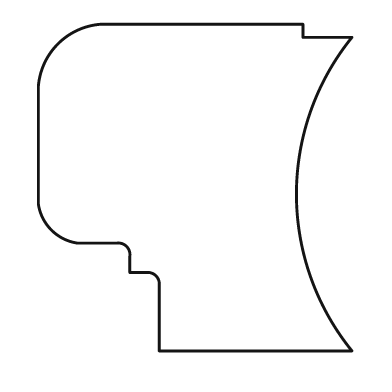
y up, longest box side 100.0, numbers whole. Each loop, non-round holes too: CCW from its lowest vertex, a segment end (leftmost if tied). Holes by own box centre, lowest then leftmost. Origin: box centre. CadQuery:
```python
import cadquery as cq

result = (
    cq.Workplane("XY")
    .moveTo(-11.0, -50.0)
    .lineTo(48.0, -50.0)
    .threePointArc((31.0, -2.0), (48.0, 46.0))
    .lineTo(33.0, 46.0)
    .lineTo(33.0, 50.0)
    .lineTo(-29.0, 50.0)
    .threePointArc((-42.0, 44.0), (-48.0, 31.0))
    .lineTo(-48.0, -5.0)
    .threePointArc((-44.0, -13.0), (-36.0, -17.0))
    .lineTo(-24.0, -17.0)
    .threePointArc((-21.0, -18.0), (-20.0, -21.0))
    .lineTo(-20.0, -26.0)
    .lineTo(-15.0, -26.0)
    .threePointArc((-12.0, -27.0), (-11.0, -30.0))
    .close()
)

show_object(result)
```